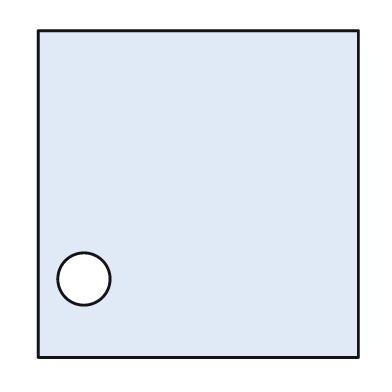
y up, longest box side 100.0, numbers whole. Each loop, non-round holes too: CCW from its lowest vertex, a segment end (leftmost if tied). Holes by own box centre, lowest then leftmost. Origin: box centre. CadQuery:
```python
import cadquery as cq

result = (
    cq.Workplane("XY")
    .moveTo(-49.0, -50.0)
    .lineTo(49.0, -50.0)
    .lineTo(49.0, 50.0)
    .lineTo(-49.0, 50.0)
    .close()
    .moveTo(-35.0, -26.0)
    .circle(8.0)
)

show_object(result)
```